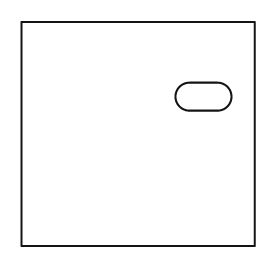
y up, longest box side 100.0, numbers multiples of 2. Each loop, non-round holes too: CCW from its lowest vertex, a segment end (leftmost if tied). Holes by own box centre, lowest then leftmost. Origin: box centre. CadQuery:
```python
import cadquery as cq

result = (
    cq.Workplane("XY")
    .moveTo(-50.0, -48.0)
    .lineTo(50.0, -48.0)
    .lineTo(50.0, 48.0)
    .lineTo(-50.0, 48.0)
    .close()
    .moveTo(22.0, 10.0)
    .lineTo(34.0, 10.0)
    .threePointArc((40.0, 16.0), (34.0, 22.0))
    .lineTo(22.0, 22.0)
    .threePointArc((16.0, 16.0), (22.0, 10.0))
    .close()
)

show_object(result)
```